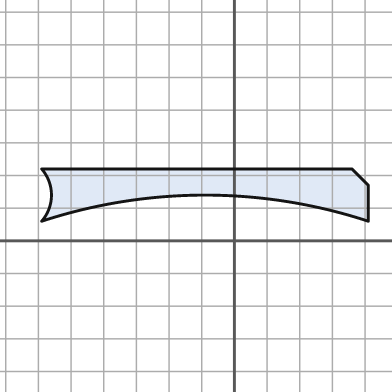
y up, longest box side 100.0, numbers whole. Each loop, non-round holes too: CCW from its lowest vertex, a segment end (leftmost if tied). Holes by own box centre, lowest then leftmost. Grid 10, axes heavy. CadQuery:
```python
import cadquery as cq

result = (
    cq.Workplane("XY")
    .moveTo(-59.0, 6.0)
    .threePointArc((-9.0, 14.0), (41.0, 6.0))
    .lineTo(41.0, 17.0)
    .lineTo(36.0, 22.0)
    .lineTo(-59.0, 22.0)
    .threePointArc((-56.0, 14.0), (-59.0, 6.0))
    .close()
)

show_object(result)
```